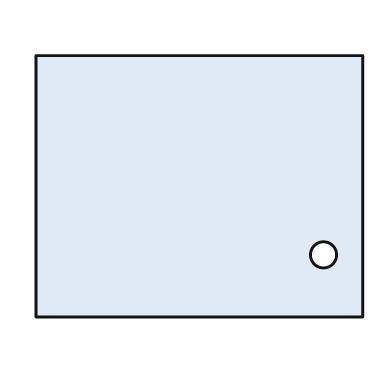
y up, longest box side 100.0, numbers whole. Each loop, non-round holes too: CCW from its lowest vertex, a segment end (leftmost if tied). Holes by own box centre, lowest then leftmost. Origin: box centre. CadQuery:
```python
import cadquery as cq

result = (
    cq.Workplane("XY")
    .moveTo(-50.0, -40.0)
    .lineTo(50.0, -40.0)
    .lineTo(50.0, 40.0)
    .lineTo(-50.0, 40.0)
    .close()
    .moveTo(38.0, -21.0)
    .circle(4.0)
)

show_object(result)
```